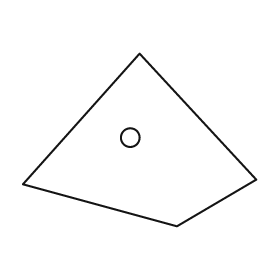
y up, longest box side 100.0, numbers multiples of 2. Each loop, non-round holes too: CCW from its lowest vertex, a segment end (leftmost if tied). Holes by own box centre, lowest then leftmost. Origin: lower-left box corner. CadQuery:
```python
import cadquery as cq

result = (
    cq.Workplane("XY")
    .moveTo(66.0, 0.0)
    .lineTo(100.0, 20.0)
    .lineTo(50.0, 74.0)
    .lineTo(0.0, 18.0)
    .close()
    .moveTo(46.0, 38.0)
    .circle(4.0)
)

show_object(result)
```